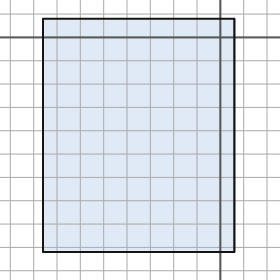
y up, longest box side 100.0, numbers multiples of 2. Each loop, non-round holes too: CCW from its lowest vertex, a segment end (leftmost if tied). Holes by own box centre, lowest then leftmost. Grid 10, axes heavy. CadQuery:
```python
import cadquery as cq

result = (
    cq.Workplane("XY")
    .moveTo(-76.0, -92.0)
    .lineTo(6.0, -92.0)
    .lineTo(6.0, 8.0)
    .lineTo(-76.0, 8.0)
    .close()
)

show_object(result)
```